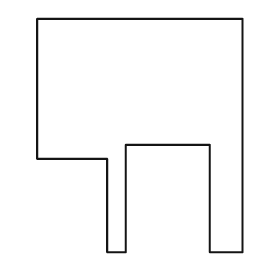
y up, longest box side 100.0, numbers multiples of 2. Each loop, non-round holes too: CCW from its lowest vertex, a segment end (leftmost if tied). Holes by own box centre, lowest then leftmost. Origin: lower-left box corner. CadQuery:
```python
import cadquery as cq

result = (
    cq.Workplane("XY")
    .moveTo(30.0, 0.0)
    .lineTo(38.0, 0.0)
    .lineTo(38.0, 46.0)
    .lineTo(74.0, 46.0)
    .lineTo(74.0, 0.0)
    .lineTo(88.0, 0.0)
    .lineTo(88.0, 100.0)
    .lineTo(0.0, 100.0)
    .lineTo(0.0, 40.0)
    .lineTo(30.0, 40.0)
    .close()
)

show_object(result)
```